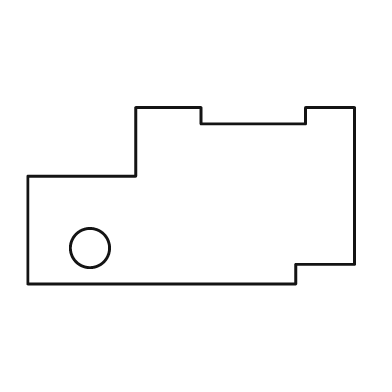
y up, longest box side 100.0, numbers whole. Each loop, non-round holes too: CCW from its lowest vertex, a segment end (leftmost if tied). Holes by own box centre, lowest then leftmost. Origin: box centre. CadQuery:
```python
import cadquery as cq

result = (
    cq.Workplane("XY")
    .moveTo(-50.0, -27.0)
    .lineTo(32.0, -27.0)
    .lineTo(32.0, -21.0)
    .lineTo(50.0, -21.0)
    .lineTo(50.0, 27.0)
    .lineTo(35.0, 27.0)
    .lineTo(35.0, 22.0)
    .lineTo(3.0, 22.0)
    .lineTo(3.0, 27.0)
    .lineTo(-17.0, 27.0)
    .lineTo(-17.0, 6.0)
    .lineTo(-50.0, 6.0)
    .close()
    .moveTo(-31.0, -16.0)
    .circle(6.0)
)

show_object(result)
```